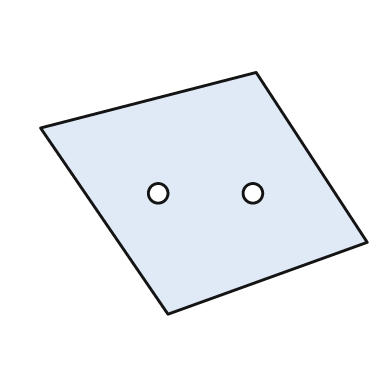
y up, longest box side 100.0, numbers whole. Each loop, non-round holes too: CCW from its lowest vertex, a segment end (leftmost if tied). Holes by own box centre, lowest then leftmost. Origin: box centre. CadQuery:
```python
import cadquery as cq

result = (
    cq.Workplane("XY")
    .moveTo(-11.0, -37.0)
    .lineTo(50.0, -15.0)
    .lineTo(16.0, 37.0)
    .lineTo(-50.0, 20.0)
    .close()
    .moveTo(-14.0, 0.0)
    .circle(3.0)
    .moveTo(15.0, 0.0)
    .circle(3.0)
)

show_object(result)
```